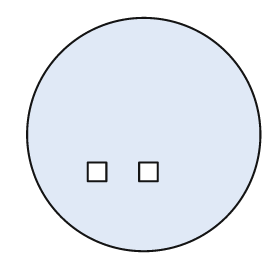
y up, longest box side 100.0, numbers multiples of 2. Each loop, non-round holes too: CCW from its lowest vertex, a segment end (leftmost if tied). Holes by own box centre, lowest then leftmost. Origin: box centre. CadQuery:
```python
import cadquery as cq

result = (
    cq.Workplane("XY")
    .moveTo(0.0, 0.0)
    .circle(50.0)
    .moveTo(-24.0, -20.0)
    .lineTo(-16.0, -20.0)
    .lineTo(-16.0, -12.0)
    .lineTo(-24.0, -12.0)
    .close()
    .moveTo(-2.0, -20.0)
    .lineTo(6.0, -20.0)
    .lineTo(6.0, -12.0)
    .lineTo(-2.0, -12.0)
    .close()
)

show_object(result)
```